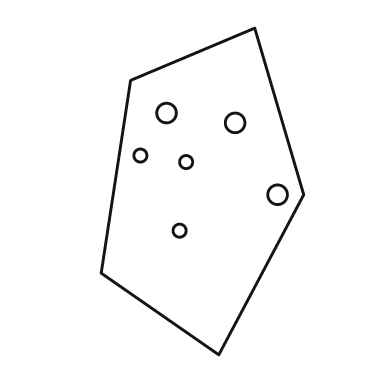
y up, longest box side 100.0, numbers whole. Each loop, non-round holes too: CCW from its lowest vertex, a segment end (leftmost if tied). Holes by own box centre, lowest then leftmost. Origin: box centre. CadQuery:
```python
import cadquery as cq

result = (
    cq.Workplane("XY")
    .moveTo(5.0, -50.0)
    .lineTo(31.0, -1.0)
    .lineTo(16.0, 50.0)
    .lineTo(-22.0, 34.0)
    .lineTo(-31.0, -25.0)
    .close()
    .moveTo(-7.0, -12.0)
    .circle(2.0)
    .moveTo(23.0, -1.0)
    .circle(3.0)
    .moveTo(-5.0, 9.0)
    .circle(2.0)
    .moveTo(-19.0, 11.0)
    .circle(2.0)
    .moveTo(10.0, 21.0)
    .circle(3.0)
    .moveTo(-11.0, 24.0)
    .circle(3.0)
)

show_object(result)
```